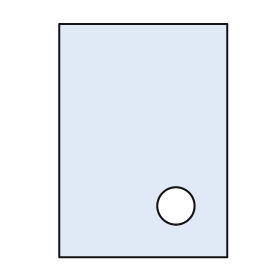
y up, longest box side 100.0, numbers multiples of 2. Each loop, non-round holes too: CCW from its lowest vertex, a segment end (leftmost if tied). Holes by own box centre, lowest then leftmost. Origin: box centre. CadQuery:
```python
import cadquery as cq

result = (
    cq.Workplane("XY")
    .moveTo(-36.0, -50.0)
    .lineTo(36.0, -50.0)
    .lineTo(36.0, 50.0)
    .lineTo(-36.0, 50.0)
    .close()
    .moveTo(14.0, -28.0)
    .circle(8.0)
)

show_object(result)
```